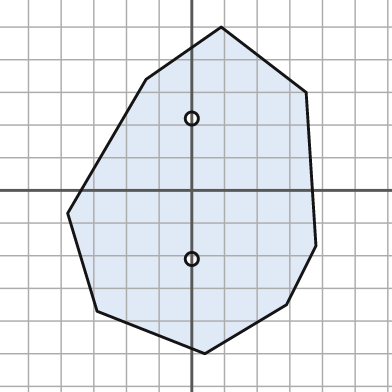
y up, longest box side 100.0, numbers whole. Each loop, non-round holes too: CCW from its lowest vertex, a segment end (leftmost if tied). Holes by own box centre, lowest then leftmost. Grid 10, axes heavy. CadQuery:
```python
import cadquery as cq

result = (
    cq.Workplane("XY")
    .moveTo(4.0, -50.0)
    .lineTo(29.0, -35.0)
    .lineTo(38.0, -17.0)
    .lineTo(35.0, 30.0)
    .lineTo(9.0, 50.0)
    .lineTo(-14.0, 34.0)
    .lineTo(-38.0, -7.0)
    .lineTo(-29.0, -37.0)
    .close()
    .moveTo(0.0, -21.0)
    .circle(2.0)
    .moveTo(0.0, 22.0)
    .circle(2.0)
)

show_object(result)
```